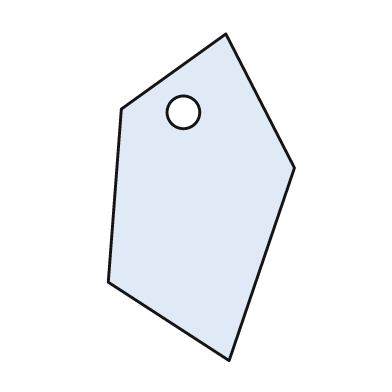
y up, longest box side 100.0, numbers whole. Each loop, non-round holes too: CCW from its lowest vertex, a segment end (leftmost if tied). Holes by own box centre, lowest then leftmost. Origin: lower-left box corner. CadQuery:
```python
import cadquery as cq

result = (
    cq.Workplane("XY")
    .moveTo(37.0, 0.0)
    .lineTo(57.0, 59.0)
    .lineTo(36.0, 100.0)
    .lineTo(4.0, 77.0)
    .lineTo(0.0, 24.0)
    .close()
    .moveTo(23.0, 76.0)
    .circle(5.0)
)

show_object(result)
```